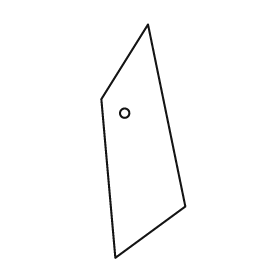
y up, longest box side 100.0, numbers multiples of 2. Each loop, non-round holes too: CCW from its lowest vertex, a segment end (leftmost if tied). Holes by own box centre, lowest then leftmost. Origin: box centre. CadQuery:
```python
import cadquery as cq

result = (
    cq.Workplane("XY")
    .moveTo(-12.0, -50.0)
    .lineTo(18.0, -28.0)
    .lineTo(2.0, 50.0)
    .lineTo(-18.0, 18.0)
    .close()
    .moveTo(-8.0, 12.0)
    .circle(2.0)
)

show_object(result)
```